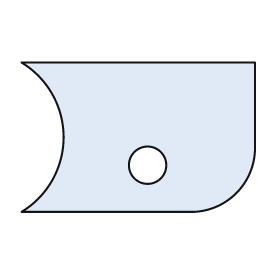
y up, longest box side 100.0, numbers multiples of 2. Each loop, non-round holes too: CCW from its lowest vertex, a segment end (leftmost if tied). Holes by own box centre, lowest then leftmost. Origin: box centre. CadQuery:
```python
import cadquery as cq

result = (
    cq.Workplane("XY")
    .moveTo(-50.0, -32.0)
    .lineTo(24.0, -32.0)
    .threePointArc((42.0, -24.0), (50.0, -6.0))
    .lineTo(50.0, 32.0)
    .lineTo(-50.0, 32.0)
    .threePointArc((-32.0, 0.0), (-50.0, -32.0))
    .close()
    .moveTo(4.0, -12.0)
    .circle(8.0)
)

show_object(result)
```